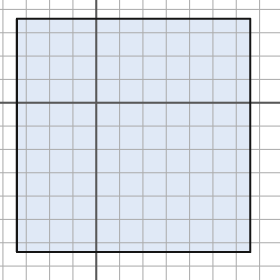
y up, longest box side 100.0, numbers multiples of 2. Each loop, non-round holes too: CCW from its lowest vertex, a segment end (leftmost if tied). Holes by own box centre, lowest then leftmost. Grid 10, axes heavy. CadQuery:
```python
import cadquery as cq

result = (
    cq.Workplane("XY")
    .moveTo(-34.0, -64.0)
    .lineTo(66.0, -64.0)
    .lineTo(66.0, 36.0)
    .lineTo(-34.0, 36.0)
    .close()
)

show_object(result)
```